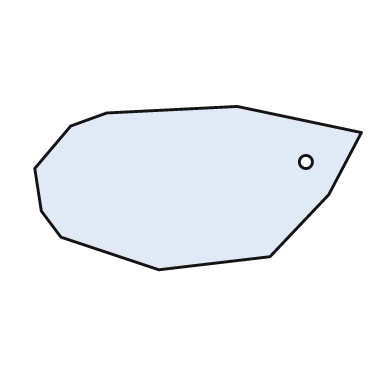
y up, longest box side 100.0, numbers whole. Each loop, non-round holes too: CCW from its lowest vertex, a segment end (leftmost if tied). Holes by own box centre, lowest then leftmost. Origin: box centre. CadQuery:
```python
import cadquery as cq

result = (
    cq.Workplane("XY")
    .moveTo(-12.0, -25.0)
    .lineTo(22.0, -21.0)
    .lineTo(40.0, -2.0)
    .lineTo(50.0, 17.0)
    .lineTo(12.0, 25.0)
    .lineTo(-28.0, 23.0)
    .lineTo(-39.0, 19.0)
    .lineTo(-50.0, 6.0)
    .lineTo(-48.0, -7.0)
    .lineTo(-42.0, -15.0)
    .close()
    .moveTo(33.0, 8.0)
    .circle(2.0)
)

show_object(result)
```